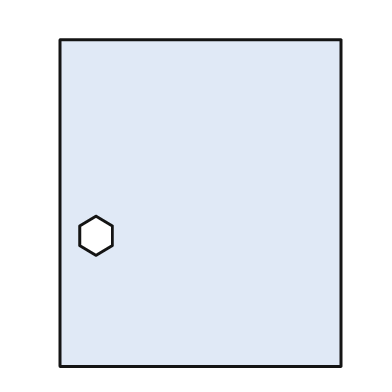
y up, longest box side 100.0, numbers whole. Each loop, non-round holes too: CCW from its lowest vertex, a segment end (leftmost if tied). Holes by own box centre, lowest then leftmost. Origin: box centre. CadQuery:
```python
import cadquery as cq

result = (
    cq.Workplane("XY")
    .moveTo(-43.0, -50.0)
    .lineTo(43.0, -50.0)
    .lineTo(43.0, 50.0)
    .lineTo(-43.0, 50.0)
    .close()
    .moveTo(-32.0, -16.0)
    .lineTo(-27.0, -13.0)
    .lineTo(-27.0, -7.0)
    .lineTo(-32.0, -4.0)
    .lineTo(-37.0, -7.0)
    .lineTo(-37.0, -13.0)
    .close()
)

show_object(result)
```